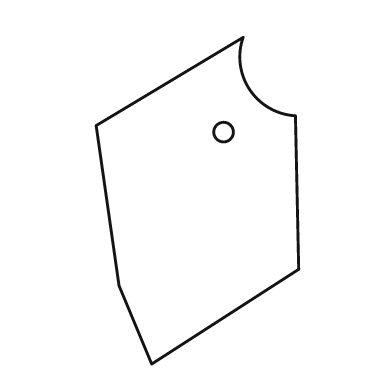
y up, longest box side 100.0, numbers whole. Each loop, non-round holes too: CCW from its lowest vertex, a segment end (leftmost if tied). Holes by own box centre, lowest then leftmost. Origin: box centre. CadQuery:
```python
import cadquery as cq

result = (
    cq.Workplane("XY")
    .moveTo(-14.0, -50.0)
    .lineTo(31.0, -21.0)
    .lineTo(30.0, 26.0)
    .threePointArc((16.0, 34.0), (14.0, 50.0))
    .lineTo(-31.0, 23.0)
    .lineTo(-24.0, -26.0)
    .close()
    .moveTo(8.0, 21.0)
    .circle(3.0)
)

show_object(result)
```